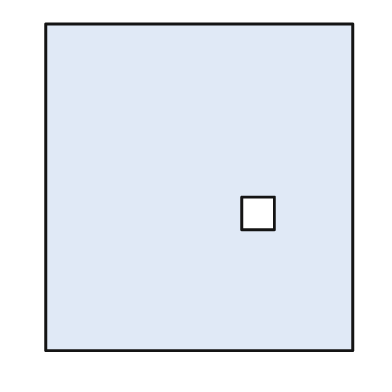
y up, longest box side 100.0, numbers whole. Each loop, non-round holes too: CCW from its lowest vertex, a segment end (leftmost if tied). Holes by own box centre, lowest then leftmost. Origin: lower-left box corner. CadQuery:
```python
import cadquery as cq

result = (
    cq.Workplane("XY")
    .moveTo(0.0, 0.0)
    .lineTo(94.0, 0.0)
    .lineTo(94.0, 100.0)
    .lineTo(0.0, 100.0)
    .close()
    .moveTo(60.0, 37.0)
    .lineTo(70.0, 37.0)
    .lineTo(70.0, 47.0)
    .lineTo(60.0, 47.0)
    .close()
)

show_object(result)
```